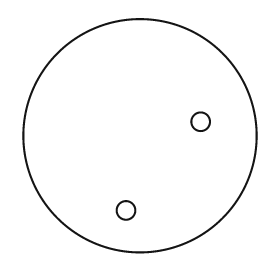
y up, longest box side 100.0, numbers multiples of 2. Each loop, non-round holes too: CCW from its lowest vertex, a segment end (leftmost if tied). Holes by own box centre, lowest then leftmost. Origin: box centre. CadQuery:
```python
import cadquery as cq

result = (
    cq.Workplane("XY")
    .moveTo(0.0, 0.0)
    .circle(50.0)
    .moveTo(-6.0, -32.0)
    .circle(4.0)
    .moveTo(26.0, 6.0)
    .circle(4.0)
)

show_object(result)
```